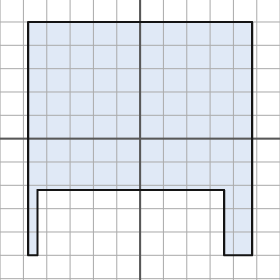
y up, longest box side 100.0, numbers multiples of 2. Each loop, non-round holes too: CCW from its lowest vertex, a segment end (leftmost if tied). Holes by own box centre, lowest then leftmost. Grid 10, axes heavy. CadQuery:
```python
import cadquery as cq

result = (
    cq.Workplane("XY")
    .moveTo(-48.0, -50.0)
    .lineTo(-44.0, -50.0)
    .lineTo(-44.0, -22.0)
    .lineTo(36.0, -22.0)
    .lineTo(36.0, -50.0)
    .lineTo(48.0, -50.0)
    .lineTo(48.0, 50.0)
    .lineTo(-48.0, 50.0)
    .close()
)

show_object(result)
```